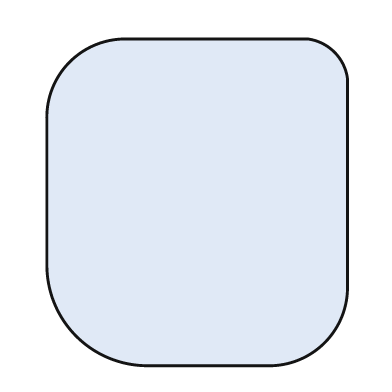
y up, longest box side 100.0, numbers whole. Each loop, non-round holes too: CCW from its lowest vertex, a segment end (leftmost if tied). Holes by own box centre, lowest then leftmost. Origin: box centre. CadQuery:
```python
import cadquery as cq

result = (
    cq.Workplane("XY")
    .moveTo(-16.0, -50.0)
    .lineTo(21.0, -50.0)
    .threePointArc((39.0, -43.0), (46.0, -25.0))
    .lineTo(46.0, 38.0)
    .threePointArc((42.0, 46.0), (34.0, 50.0))
    .lineTo(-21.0, 50.0)
    .threePointArc((-39.0, 43.0), (-46.0, 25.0))
    .lineTo(-46.0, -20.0)
    .threePointArc((-37.0, -41.0), (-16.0, -50.0))
    .close()
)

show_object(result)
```